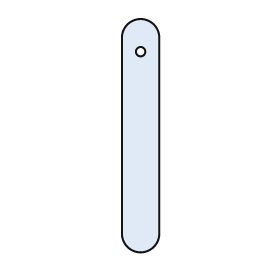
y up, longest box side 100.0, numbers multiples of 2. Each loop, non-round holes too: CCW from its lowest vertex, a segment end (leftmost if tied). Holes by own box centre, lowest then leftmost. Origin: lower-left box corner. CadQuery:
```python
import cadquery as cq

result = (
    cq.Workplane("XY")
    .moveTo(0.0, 8.0)
    .threePointArc((8.0, 0.0), (16.0, 8.0))
    .lineTo(16.0, 92.0)
    .threePointArc((8.0, 100.0), (0.0, 92.0))
    .close()
    .moveTo(8.0, 86.0)
    .circle(2.0)
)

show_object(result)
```